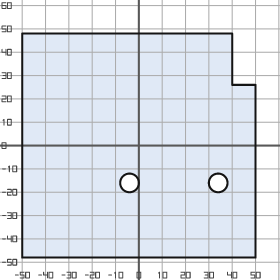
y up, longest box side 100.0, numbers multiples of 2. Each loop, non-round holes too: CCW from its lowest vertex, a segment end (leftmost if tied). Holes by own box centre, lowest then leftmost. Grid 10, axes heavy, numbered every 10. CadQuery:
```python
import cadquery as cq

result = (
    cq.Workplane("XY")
    .moveTo(-50.0, -48.0)
    .lineTo(50.0, -48.0)
    .lineTo(50.0, 26.0)
    .lineTo(40.0, 26.0)
    .lineTo(40.0, 48.0)
    .lineTo(-50.0, 48.0)
    .close()
    .moveTo(-4.0, -16.0)
    .circle(4.0)
    .moveTo(34.0, -16.0)
    .circle(4.0)
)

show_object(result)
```